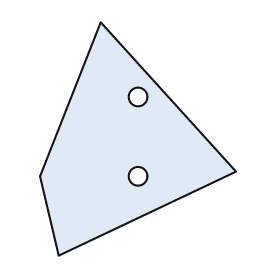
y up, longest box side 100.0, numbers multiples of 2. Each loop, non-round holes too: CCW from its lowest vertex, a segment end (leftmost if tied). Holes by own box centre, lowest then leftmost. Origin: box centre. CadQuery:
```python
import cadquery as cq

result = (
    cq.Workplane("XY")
    .moveTo(-34.0, -50.0)
    .lineTo(42.0, -14.0)
    .lineTo(-16.0, 50.0)
    .lineTo(-42.0, -16.0)
    .close()
    .moveTo(0.0, -16.0)
    .circle(4.0)
    .moveTo(0.0, 18.0)
    .circle(4.0)
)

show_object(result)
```